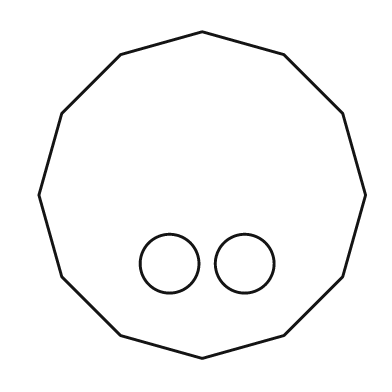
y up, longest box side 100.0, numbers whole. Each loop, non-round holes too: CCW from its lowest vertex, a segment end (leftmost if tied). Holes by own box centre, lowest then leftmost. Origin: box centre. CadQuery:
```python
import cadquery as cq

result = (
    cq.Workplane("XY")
    .moveTo(0.0, -50.0)
    .lineTo(25.0, -43.0)
    .lineTo(43.0, -25.0)
    .lineTo(50.0, 0.0)
    .lineTo(43.0, 25.0)
    .lineTo(25.0, 43.0)
    .lineTo(0.0, 50.0)
    .lineTo(-25.0, 43.0)
    .lineTo(-43.0, 25.0)
    .lineTo(-50.0, 0.0)
    .lineTo(-43.0, -25.0)
    .lineTo(-25.0, -43.0)
    .close()
    .moveTo(-10.0, -21.0)
    .circle(9.0)
    .moveTo(13.0, -21.0)
    .circle(9.0)
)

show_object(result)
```